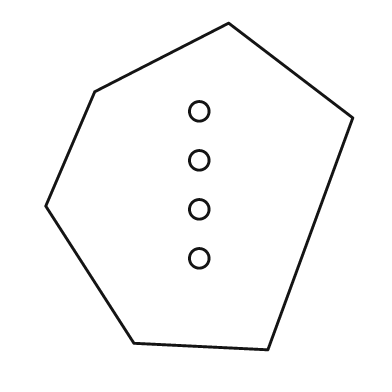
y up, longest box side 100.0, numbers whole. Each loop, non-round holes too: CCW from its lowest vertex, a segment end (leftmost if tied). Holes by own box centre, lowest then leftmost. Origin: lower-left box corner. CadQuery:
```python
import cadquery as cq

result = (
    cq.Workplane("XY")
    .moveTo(68.0, 0.0)
    .lineTo(94.0, 71.0)
    .lineTo(56.0, 100.0)
    .lineTo(15.0, 79.0)
    .lineTo(0.0, 44.0)
    .lineTo(27.0, 2.0)
    .close()
    .moveTo(47.0, 28.0)
    .circle(3.0)
    .moveTo(47.0, 43.0)
    .circle(3.0)
    .moveTo(47.0, 58.0)
    .circle(3.0)
    .moveTo(47.0, 73.0)
    .circle(3.0)
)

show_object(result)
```